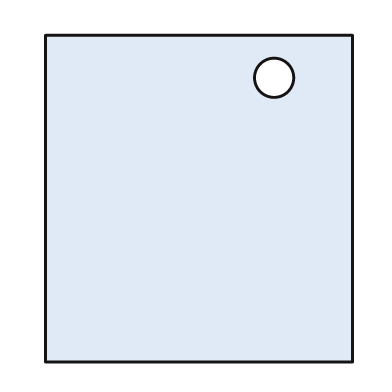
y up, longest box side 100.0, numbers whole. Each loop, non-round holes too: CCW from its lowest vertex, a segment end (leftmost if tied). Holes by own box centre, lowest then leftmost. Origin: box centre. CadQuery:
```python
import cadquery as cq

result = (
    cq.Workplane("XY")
    .moveTo(-47.0, -50.0)
    .lineTo(47.0, -50.0)
    .lineTo(47.0, 50.0)
    .lineTo(-47.0, 50.0)
    .close()
    .moveTo(23.0, 37.0)
    .circle(6.0)
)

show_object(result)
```